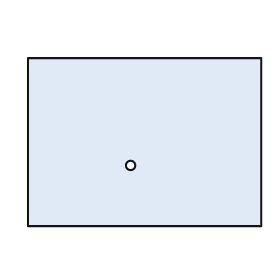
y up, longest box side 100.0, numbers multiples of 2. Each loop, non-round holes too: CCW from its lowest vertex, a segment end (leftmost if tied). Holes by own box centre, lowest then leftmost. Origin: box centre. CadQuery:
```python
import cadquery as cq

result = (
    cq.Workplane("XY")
    .moveTo(-50.0, -36.0)
    .lineTo(50.0, -36.0)
    .lineTo(50.0, 36.0)
    .lineTo(-50.0, 36.0)
    .close()
    .moveTo(-6.0, -10.0)
    .circle(2.0)
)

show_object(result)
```